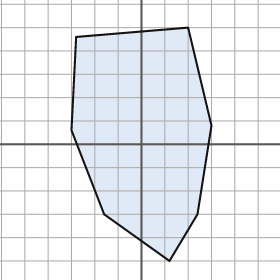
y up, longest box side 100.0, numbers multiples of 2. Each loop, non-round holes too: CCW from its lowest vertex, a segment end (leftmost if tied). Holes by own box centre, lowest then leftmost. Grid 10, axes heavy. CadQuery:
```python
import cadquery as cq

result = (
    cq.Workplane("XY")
    .moveTo(12.0, -50.0)
    .lineTo(24.0, -30.0)
    .lineTo(30.0, 8.0)
    .lineTo(20.0, 50.0)
    .lineTo(-28.0, 46.0)
    .lineTo(-30.0, 6.0)
    .lineTo(-16.0, -30.0)
    .close()
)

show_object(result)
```